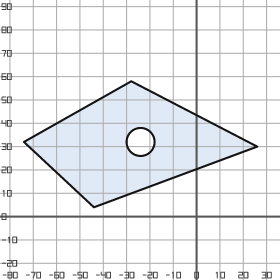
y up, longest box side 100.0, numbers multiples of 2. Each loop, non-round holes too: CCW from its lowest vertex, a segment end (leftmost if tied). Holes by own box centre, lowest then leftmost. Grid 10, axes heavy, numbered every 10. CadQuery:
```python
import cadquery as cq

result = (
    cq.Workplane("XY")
    .moveTo(-44.0, 4.0)
    .lineTo(26.0, 30.0)
    .lineTo(-28.0, 58.0)
    .lineTo(-74.0, 32.0)
    .close()
    .moveTo(-24.0, 32.0)
    .circle(6.0)
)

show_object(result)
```